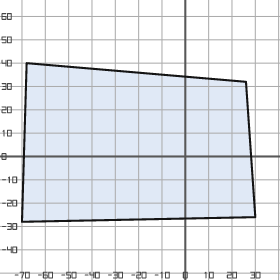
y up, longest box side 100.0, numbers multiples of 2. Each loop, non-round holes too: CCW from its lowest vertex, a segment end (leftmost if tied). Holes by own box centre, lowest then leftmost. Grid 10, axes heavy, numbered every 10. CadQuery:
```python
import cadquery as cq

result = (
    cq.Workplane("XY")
    .moveTo(-70.0, -28.0)
    .lineTo(30.0, -26.0)
    .lineTo(26.0, 32.0)
    .lineTo(-68.0, 40.0)
    .close()
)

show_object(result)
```